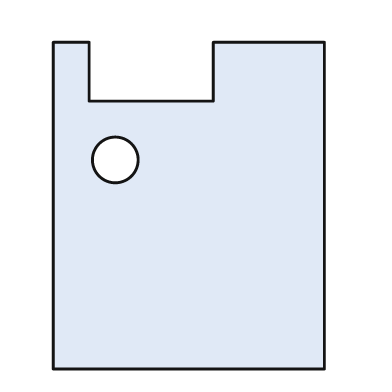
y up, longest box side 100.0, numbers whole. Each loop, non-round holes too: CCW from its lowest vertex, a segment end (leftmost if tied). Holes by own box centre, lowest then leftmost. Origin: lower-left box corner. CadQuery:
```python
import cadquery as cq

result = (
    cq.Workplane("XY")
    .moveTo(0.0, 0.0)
    .lineTo(83.0, 0.0)
    .lineTo(83.0, 100.0)
    .lineTo(49.0, 100.0)
    .lineTo(49.0, 82.0)
    .lineTo(11.0, 82.0)
    .lineTo(11.0, 100.0)
    .lineTo(0.0, 100.0)
    .close()
    .moveTo(19.0, 64.0)
    .circle(7.0)
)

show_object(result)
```